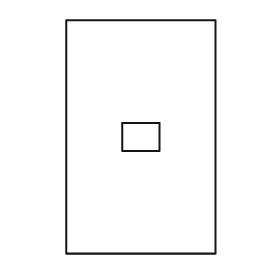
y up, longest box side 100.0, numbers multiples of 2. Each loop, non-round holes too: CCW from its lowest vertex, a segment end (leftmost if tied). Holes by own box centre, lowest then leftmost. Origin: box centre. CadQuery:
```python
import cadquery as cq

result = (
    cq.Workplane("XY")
    .moveTo(-32.0, -50.0)
    .lineTo(32.0, -50.0)
    .lineTo(32.0, 50.0)
    .lineTo(-32.0, 50.0)
    .close()
    .moveTo(-8.0, -6.0)
    .lineTo(8.0, -6.0)
    .lineTo(8.0, 6.0)
    .lineTo(-8.0, 6.0)
    .close()
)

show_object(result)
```